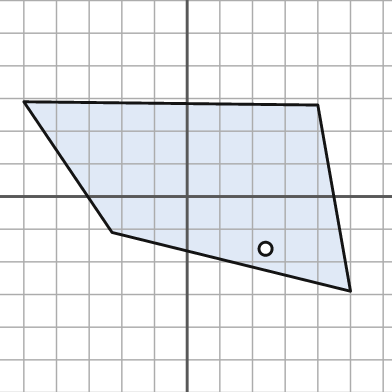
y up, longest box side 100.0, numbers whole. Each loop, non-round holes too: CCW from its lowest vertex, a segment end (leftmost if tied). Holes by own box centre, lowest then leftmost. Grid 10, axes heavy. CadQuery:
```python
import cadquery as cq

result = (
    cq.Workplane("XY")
    .moveTo(50.0, -29.0)
    .lineTo(40.0, 28.0)
    .lineTo(-50.0, 29.0)
    .lineTo(-23.0, -11.0)
    .close()
    .moveTo(24.0, -16.0)
    .circle(2.0)
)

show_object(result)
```